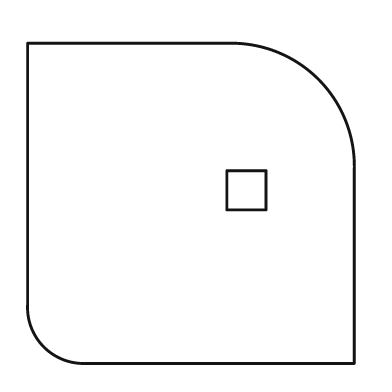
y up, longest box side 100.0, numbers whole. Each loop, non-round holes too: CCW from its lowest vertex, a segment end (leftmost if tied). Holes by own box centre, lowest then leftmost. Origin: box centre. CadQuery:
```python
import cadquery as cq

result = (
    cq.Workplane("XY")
    .moveTo(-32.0, -49.0)
    .lineTo(50.0, -49.0)
    .lineTo(50.0, 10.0)
    .threePointArc((39.0, 38.0), (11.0, 49.0))
    .lineTo(-50.0, 49.0)
    .lineTo(-50.0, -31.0)
    .threePointArc((-45.0, -44.0), (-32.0, -49.0))
    .close()
    .moveTo(11.0, -2.0)
    .lineTo(23.0, -2.0)
    .lineTo(23.0, 10.0)
    .lineTo(11.0, 10.0)
    .close()
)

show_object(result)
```